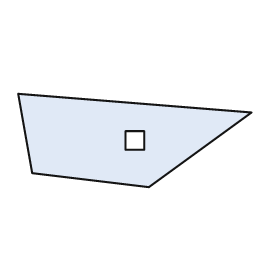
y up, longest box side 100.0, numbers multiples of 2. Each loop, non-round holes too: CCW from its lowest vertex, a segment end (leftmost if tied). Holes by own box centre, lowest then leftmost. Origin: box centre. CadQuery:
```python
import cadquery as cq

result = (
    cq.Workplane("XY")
    .moveTo(6.0, -20.0)
    .lineTo(50.0, 12.0)
    .lineTo(-50.0, 20.0)
    .lineTo(-44.0, -14.0)
    .close()
    .moveTo(-4.0, -4.0)
    .lineTo(4.0, -4.0)
    .lineTo(4.0, 4.0)
    .lineTo(-4.0, 4.0)
    .close()
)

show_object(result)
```